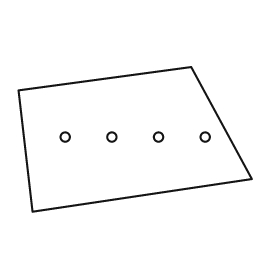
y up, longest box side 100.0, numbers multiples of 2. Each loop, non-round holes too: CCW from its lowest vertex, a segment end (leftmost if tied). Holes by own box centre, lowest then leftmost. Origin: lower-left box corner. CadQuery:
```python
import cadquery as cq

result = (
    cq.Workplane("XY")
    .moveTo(6.0, 0.0)
    .lineTo(100.0, 14.0)
    .lineTo(74.0, 62.0)
    .lineTo(0.0, 52.0)
    .close()
    .moveTo(20.0, 32.0)
    .circle(2.0)
    .moveTo(40.0, 32.0)
    .circle(2.0)
    .moveTo(60.0, 32.0)
    .circle(2.0)
    .moveTo(80.0, 32.0)
    .circle(2.0)
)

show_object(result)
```